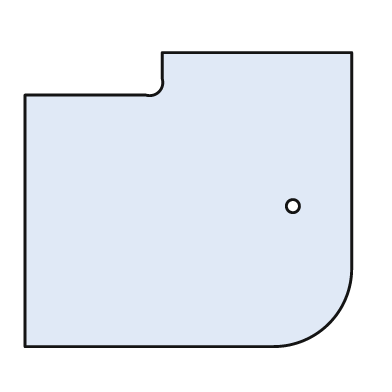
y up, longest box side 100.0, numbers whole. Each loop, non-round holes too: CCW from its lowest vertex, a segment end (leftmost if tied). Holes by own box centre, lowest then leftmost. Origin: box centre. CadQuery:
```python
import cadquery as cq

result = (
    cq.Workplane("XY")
    .moveTo(-50.0, -45.0)
    .lineTo(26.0, -45.0)
    .threePointArc((43.0, -38.0), (50.0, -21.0))
    .lineTo(50.0, 45.0)
    .lineTo(-8.0, 45.0)
    .lineTo(-8.0, 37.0)
    .threePointArc((-9.0, 33.0), (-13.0, 32.0))
    .lineTo(-50.0, 32.0)
    .close()
    .moveTo(32.0, -2.0)
    .circle(2.0)
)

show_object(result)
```